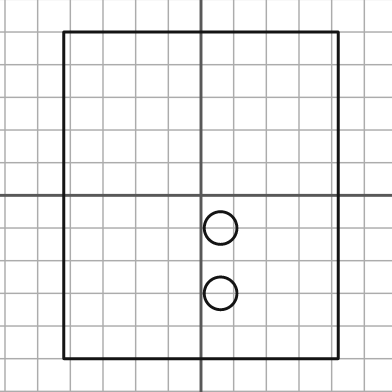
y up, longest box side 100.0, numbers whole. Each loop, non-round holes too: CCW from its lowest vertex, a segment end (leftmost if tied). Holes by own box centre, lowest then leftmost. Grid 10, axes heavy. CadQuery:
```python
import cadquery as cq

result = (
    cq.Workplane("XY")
    .moveTo(-42.0, -50.0)
    .lineTo(42.0, -50.0)
    .lineTo(42.0, 50.0)
    .lineTo(-42.0, 50.0)
    .close()
    .moveTo(6.0, -30.0)
    .circle(5.0)
    .moveTo(6.0, -10.0)
    .circle(5.0)
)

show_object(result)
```